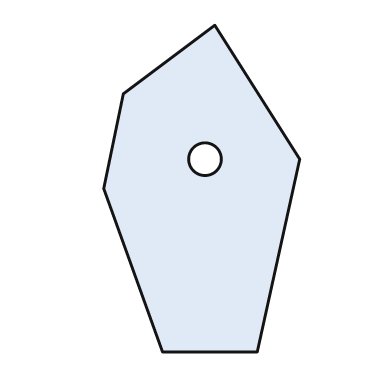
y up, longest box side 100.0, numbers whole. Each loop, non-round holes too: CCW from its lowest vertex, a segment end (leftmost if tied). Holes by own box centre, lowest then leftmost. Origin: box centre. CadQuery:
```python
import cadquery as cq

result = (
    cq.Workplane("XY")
    .moveTo(-12.0, -50.0)
    .lineTo(17.0, -50.0)
    .lineTo(30.0, 9.0)
    .lineTo(4.0, 50.0)
    .lineTo(-24.0, 29.0)
    .lineTo(-30.0, 0.0)
    .close()
    .moveTo(1.0, 9.0)
    .circle(5.0)
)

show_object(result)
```